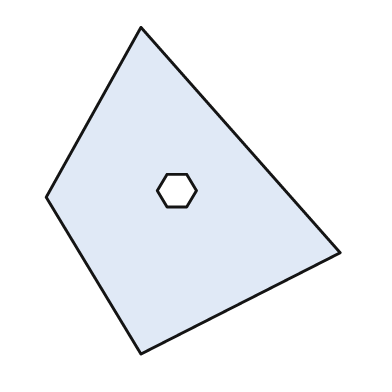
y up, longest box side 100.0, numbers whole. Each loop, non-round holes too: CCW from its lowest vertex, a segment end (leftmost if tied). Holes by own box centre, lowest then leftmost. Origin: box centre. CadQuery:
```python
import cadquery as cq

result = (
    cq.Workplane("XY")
    .moveTo(-16.0, -50.0)
    .lineTo(45.0, -19.0)
    .lineTo(-16.0, 50.0)
    .lineTo(-45.0, -2.0)
    .close()
    .moveTo(-8.0, -5.0)
    .lineTo(-2.0, -5.0)
    .lineTo(1.0, 0.0)
    .lineTo(-2.0, 5.0)
    .lineTo(-8.0, 5.0)
    .lineTo(-11.0, 0.0)
    .close()
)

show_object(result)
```